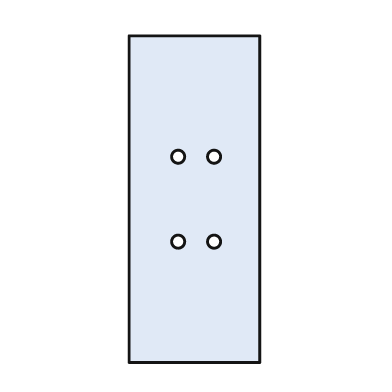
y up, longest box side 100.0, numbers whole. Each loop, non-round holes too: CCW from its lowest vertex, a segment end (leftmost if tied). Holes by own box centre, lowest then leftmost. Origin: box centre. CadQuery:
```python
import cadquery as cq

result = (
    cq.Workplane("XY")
    .moveTo(-20.0, -50.0)
    .lineTo(20.0, -50.0)
    .lineTo(20.0, 50.0)
    .lineTo(-20.0, 50.0)
    .close()
    .moveTo(-5.0, -13.0)
    .circle(2.0)
    .moveTo(6.0, -13.0)
    .circle(2.0)
    .moveTo(-5.0, 13.0)
    .circle(2.0)
    .moveTo(6.0, 13.0)
    .circle(2.0)
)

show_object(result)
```